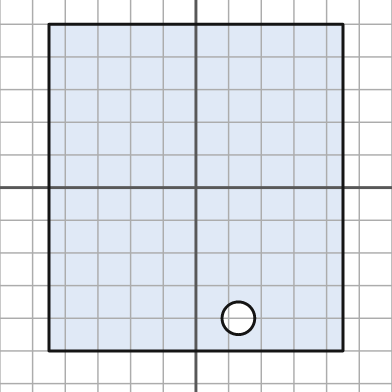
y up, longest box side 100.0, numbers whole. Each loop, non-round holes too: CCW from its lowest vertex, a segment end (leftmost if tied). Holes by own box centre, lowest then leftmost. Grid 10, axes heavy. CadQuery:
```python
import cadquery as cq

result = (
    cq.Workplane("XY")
    .moveTo(-45.0, -50.0)
    .lineTo(45.0, -50.0)
    .lineTo(45.0, 50.0)
    .lineTo(-45.0, 50.0)
    .close()
    .moveTo(13.0, -40.0)
    .circle(5.0)
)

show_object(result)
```